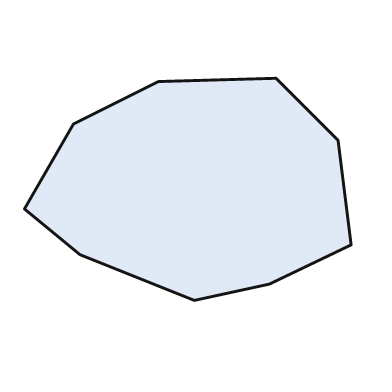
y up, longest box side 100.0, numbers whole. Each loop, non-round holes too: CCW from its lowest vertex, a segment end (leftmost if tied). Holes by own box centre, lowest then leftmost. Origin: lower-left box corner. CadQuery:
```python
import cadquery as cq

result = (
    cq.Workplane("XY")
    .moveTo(52.0, 0.0)
    .lineTo(75.0, 5.0)
    .lineTo(100.0, 17.0)
    .lineTo(96.0, 49.0)
    .lineTo(77.0, 68.0)
    .lineTo(41.0, 67.0)
    .lineTo(15.0, 54.0)
    .lineTo(0.0, 28.0)
    .lineTo(17.0, 14.0)
    .close()
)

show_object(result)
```